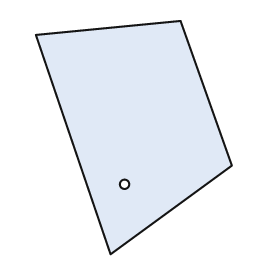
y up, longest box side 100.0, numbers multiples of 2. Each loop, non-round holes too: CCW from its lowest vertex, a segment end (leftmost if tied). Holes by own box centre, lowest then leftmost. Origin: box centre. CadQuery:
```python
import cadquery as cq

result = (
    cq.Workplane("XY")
    .moveTo(-10.0, -50.0)
    .lineTo(42.0, -12.0)
    .lineTo(20.0, 50.0)
    .lineTo(-42.0, 44.0)
    .close()
    .moveTo(-4.0, -20.0)
    .circle(2.0)
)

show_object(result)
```